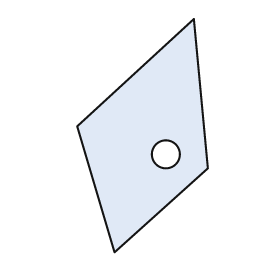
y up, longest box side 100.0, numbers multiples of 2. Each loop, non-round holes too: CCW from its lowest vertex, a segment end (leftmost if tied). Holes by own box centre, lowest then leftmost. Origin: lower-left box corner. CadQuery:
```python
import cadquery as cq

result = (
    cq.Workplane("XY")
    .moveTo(16.0, 0.0)
    .lineTo(56.0, 36.0)
    .lineTo(50.0, 100.0)
    .lineTo(0.0, 54.0)
    .close()
    .moveTo(38.0, 42.0)
    .circle(6.0)
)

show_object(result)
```